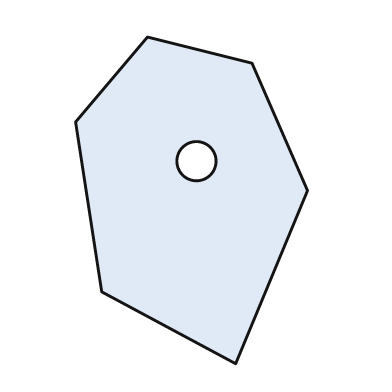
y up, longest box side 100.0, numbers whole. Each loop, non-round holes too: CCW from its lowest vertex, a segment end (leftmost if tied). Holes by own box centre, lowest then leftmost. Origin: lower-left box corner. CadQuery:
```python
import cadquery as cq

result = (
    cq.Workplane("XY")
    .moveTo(49.0, 0.0)
    .lineTo(71.0, 53.0)
    .lineTo(54.0, 92.0)
    .lineTo(22.0, 100.0)
    .lineTo(0.0, 74.0)
    .lineTo(8.0, 22.0)
    .close()
    .moveTo(37.0, 62.0)
    .circle(6.0)
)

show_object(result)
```